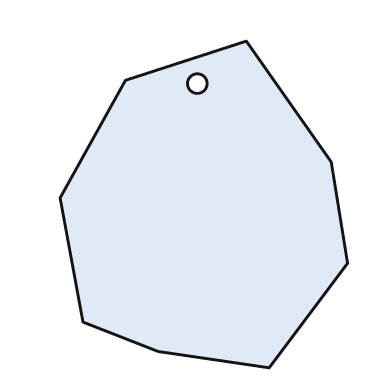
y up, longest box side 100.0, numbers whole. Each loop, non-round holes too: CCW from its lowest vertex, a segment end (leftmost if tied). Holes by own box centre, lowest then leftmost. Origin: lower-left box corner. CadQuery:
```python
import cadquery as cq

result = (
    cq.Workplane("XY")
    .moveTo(64.0, 0.0)
    .lineTo(88.0, 32.0)
    .lineTo(83.0, 63.0)
    .lineTo(57.0, 100.0)
    .lineTo(20.0, 88.0)
    .lineTo(0.0, 52.0)
    .lineTo(7.0, 14.0)
    .lineTo(30.0, 5.0)
    .close()
    .moveTo(42.0, 87.0)
    .circle(3.0)
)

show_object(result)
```